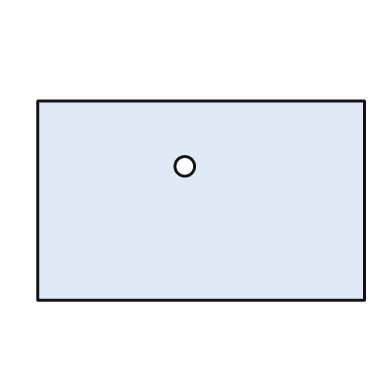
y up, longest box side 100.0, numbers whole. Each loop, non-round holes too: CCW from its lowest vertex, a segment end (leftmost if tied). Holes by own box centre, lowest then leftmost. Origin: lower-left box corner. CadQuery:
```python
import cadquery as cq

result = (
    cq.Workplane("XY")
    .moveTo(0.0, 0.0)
    .lineTo(100.0, 0.0)
    .lineTo(100.0, 61.0)
    .lineTo(0.0, 61.0)
    .close()
    .moveTo(45.0, 41.0)
    .circle(3.0)
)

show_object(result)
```